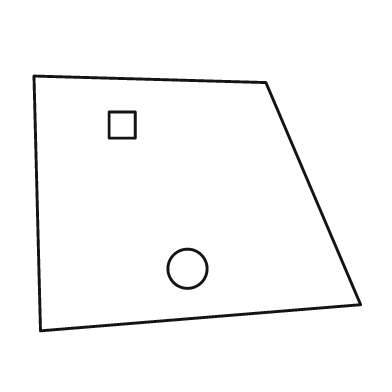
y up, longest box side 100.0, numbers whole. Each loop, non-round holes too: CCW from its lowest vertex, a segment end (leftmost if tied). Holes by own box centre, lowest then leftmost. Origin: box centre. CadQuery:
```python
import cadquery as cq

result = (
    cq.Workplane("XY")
    .moveTo(-48.0, -39.0)
    .lineTo(50.0, -31.0)
    .lineTo(21.0, 37.0)
    .lineTo(-50.0, 39.0)
    .close()
    .moveTo(-3.0, -20.0)
    .circle(6.0)
    .moveTo(-27.0, 20.0)
    .lineTo(-19.0, 20.0)
    .lineTo(-19.0, 28.0)
    .lineTo(-27.0, 28.0)
    .close()
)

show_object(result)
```